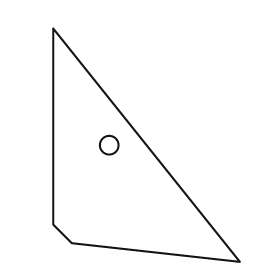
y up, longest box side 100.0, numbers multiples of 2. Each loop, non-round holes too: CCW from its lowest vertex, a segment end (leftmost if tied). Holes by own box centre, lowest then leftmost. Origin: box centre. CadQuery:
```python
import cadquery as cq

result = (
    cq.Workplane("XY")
    .moveTo(40.0, -50.0)
    .lineTo(-40.0, 50.0)
    .lineTo(-40.0, -34.0)
    .lineTo(-32.0, -42.0)
    .close()
    .moveTo(-16.0, 0.0)
    .circle(4.0)
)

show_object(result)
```